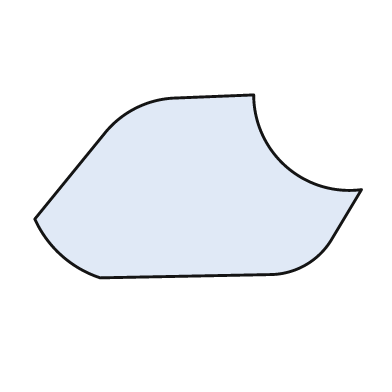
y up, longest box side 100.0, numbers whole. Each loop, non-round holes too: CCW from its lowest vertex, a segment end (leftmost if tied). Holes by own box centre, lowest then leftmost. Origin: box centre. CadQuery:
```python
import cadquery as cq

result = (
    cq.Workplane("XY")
    .moveTo(-30.0, -28.0)
    .lineTo(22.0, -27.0)
    .threePointArc((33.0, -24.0), (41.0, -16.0))
    .lineTo(50.0, -1.0)
    .threePointArc((27.0, 6.0), (17.0, 28.0))
    .lineTo(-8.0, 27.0)
    .threePointArc((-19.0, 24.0), (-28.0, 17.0))
    .lineTo(-50.0, -10.0)
    .threePointArc((-42.0, -21.0), (-30.0, -28.0))
    .close()
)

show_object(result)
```